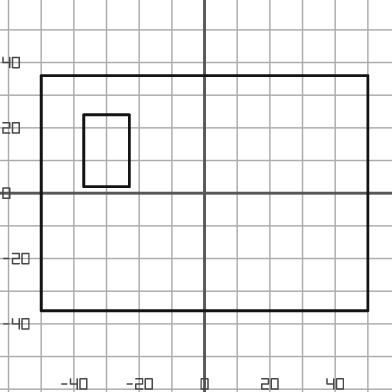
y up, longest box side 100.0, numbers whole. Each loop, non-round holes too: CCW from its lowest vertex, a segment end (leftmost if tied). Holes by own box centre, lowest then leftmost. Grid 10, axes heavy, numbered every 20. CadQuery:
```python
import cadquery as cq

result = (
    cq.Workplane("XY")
    .moveTo(-50.0, -36.0)
    .lineTo(50.0, -36.0)
    .lineTo(50.0, 36.0)
    .lineTo(-50.0, 36.0)
    .close()
    .moveTo(-37.0, 2.0)
    .lineTo(-23.0, 2.0)
    .lineTo(-23.0, 24.0)
    .lineTo(-37.0, 24.0)
    .close()
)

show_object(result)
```